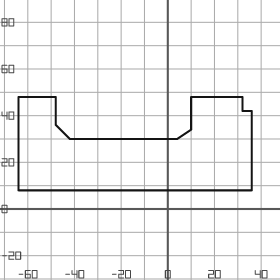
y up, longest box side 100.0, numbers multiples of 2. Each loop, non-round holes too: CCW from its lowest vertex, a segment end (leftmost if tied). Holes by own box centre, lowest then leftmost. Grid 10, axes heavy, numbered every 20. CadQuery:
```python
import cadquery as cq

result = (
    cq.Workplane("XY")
    .moveTo(-64.0, 8.0)
    .lineTo(36.0, 8.0)
    .lineTo(36.0, 42.0)
    .lineTo(32.0, 42.0)
    .lineTo(32.0, 48.0)
    .lineTo(10.0, 48.0)
    .lineTo(10.0, 34.0)
    .lineTo(4.0, 30.0)
    .lineTo(-42.0, 30.0)
    .lineTo(-48.0, 36.0)
    .lineTo(-48.0, 48.0)
    .lineTo(-64.0, 48.0)
    .close()
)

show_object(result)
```